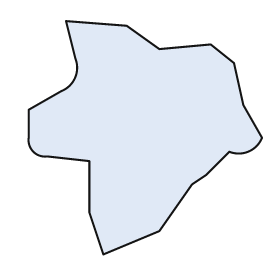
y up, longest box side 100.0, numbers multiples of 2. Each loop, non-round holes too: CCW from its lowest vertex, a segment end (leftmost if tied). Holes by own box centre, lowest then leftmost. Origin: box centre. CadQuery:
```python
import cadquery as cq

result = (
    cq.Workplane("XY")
    .moveTo(-18.0, -50.0)
    .lineTo(6.0, -40.0)
    .lineTo(20.0, -20.0)
    .lineTo(26.0, -16.0)
    .lineTo(36.0, -6.0)
    .threePointArc((44.0, -6.0), (50.0, 0.0))
    .lineTo(42.0, 14.0)
    .lineTo(38.0, 32.0)
    .lineTo(28.0, 40.0)
    .lineTo(6.0, 38.0)
    .lineTo(-8.0, 48.0)
    .lineTo(-34.0, 50.0)
    .lineTo(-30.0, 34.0)
    .threePointArc((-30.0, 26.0), (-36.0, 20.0))
    .lineTo(-50.0, 12.0)
    .lineTo(-50.0, 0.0)
    .threePointArc((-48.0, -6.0), (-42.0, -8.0))
    .lineTo(-24.0, -10.0)
    .lineTo(-24.0, -32.0)
    .close()
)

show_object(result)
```